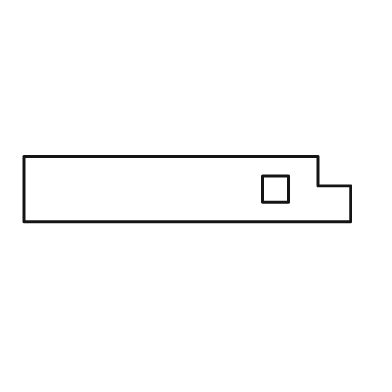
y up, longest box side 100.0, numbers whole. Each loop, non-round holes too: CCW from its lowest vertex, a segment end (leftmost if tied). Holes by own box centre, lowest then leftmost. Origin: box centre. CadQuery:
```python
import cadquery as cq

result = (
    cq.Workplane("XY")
    .moveTo(-50.0, -10.0)
    .lineTo(50.0, -10.0)
    .lineTo(50.0, 1.0)
    .lineTo(40.0, 1.0)
    .lineTo(40.0, 10.0)
    .lineTo(-50.0, 10.0)
    .close()
    .moveTo(23.0, -4.0)
    .lineTo(31.0, -4.0)
    .lineTo(31.0, 4.0)
    .lineTo(23.0, 4.0)
    .close()
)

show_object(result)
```